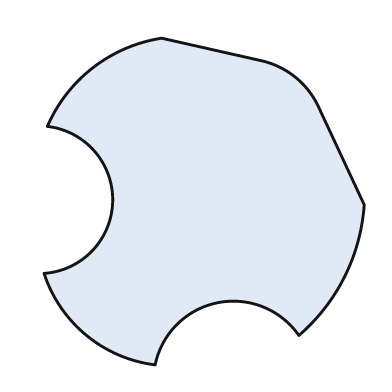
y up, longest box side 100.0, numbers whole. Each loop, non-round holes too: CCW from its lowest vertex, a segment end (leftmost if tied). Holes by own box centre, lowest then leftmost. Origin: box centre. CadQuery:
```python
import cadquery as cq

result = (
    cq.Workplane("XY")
    .moveTo(-15.0, -50.0)
    .threePointArc((4.0, -31.0), (29.0, -41.0))
    .threePointArc((43.0, -23.0), (49.0, -1.0))
    .lineTo(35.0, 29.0)
    .threePointArc((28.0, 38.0), (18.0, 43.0))
    .lineTo(-13.0, 50.0)
    .threePointArc((-34.0, 41.0), (-48.0, 23.0))
    .threePointArc((-28.0, 0.0), (-49.0, -22.0))
    .threePointArc((-36.0, -41.0), (-15.0, -50.0))
    .close()
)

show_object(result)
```